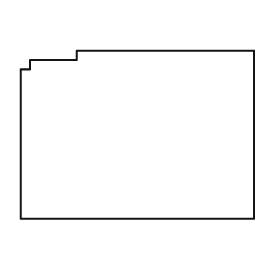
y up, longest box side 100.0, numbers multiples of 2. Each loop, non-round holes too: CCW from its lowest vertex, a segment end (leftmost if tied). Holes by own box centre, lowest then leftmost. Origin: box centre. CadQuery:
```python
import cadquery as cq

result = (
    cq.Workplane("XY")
    .moveTo(-50.0, -36.0)
    .lineTo(50.0, -36.0)
    .lineTo(50.0, 36.0)
    .lineTo(-26.0, 36.0)
    .lineTo(-26.0, 32.0)
    .lineTo(-46.0, 32.0)
    .lineTo(-46.0, 28.0)
    .lineTo(-50.0, 28.0)
    .close()
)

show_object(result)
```